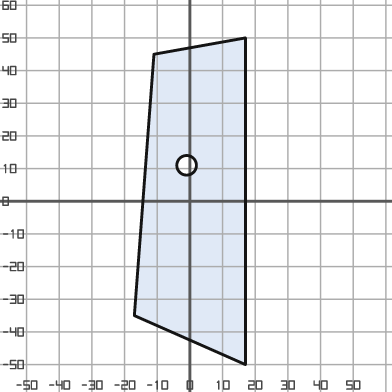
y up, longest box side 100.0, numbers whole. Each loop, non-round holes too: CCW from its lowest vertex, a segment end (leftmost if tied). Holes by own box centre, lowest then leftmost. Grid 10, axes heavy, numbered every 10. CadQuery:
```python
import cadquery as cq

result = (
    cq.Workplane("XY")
    .moveTo(17.0, -50.0)
    .lineTo(17.0, 50.0)
    .lineTo(-11.0, 45.0)
    .lineTo(-17.0, -35.0)
    .close()
    .moveTo(-1.0, 11.0)
    .circle(3.0)
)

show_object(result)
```